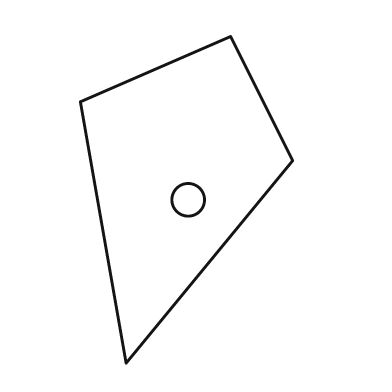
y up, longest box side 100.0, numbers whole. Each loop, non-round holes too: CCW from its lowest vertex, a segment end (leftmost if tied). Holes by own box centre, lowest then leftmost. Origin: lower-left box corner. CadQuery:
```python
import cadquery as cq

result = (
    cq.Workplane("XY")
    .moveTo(14.0, 0.0)
    .lineTo(65.0, 62.0)
    .lineTo(46.0, 100.0)
    .lineTo(0.0, 80.0)
    .close()
    .moveTo(33.0, 50.0)
    .circle(5.0)
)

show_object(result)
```